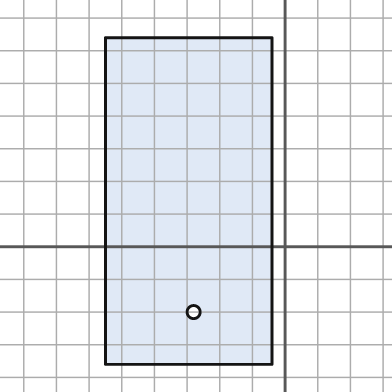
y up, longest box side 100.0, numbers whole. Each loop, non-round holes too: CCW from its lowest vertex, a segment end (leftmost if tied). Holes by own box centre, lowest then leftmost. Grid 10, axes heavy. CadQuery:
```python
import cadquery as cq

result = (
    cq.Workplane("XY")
    .moveTo(-55.0, -36.0)
    .lineTo(-4.0, -36.0)
    .lineTo(-4.0, 64.0)
    .lineTo(-55.0, 64.0)
    .close()
    .moveTo(-28.0, -20.0)
    .circle(2.0)
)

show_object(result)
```